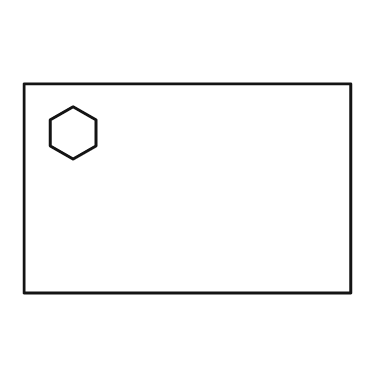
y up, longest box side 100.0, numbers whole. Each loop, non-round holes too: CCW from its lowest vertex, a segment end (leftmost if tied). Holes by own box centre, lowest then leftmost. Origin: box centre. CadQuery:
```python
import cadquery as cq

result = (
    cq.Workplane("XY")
    .moveTo(-50.0, -32.0)
    .lineTo(50.0, -32.0)
    .lineTo(50.0, 32.0)
    .lineTo(-50.0, 32.0)
    .close()
    .moveTo(-35.0, 9.0)
    .lineTo(-28.0, 13.0)
    .lineTo(-28.0, 21.0)
    .lineTo(-35.0, 25.0)
    .lineTo(-42.0, 21.0)
    .lineTo(-42.0, 13.0)
    .close()
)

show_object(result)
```